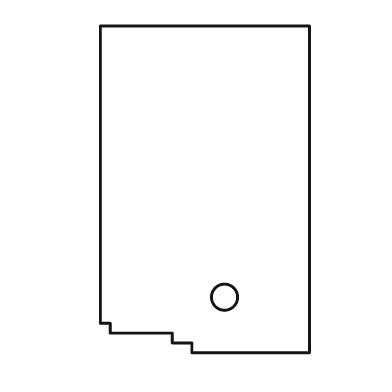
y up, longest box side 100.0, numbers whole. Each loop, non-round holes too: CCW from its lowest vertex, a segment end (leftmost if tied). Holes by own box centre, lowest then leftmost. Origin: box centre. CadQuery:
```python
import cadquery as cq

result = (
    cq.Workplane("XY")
    .moveTo(-4.0, -50.0)
    .lineTo(32.0, -50.0)
    .lineTo(32.0, 50.0)
    .lineTo(-32.0, 50.0)
    .lineTo(-32.0, -41.0)
    .lineTo(-29.0, -41.0)
    .lineTo(-29.0, -44.0)
    .lineTo(-10.0, -44.0)
    .lineTo(-10.0, -47.0)
    .lineTo(-4.0, -47.0)
    .close()
    .moveTo(6.0, -33.0)
    .circle(4.0)
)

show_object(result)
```